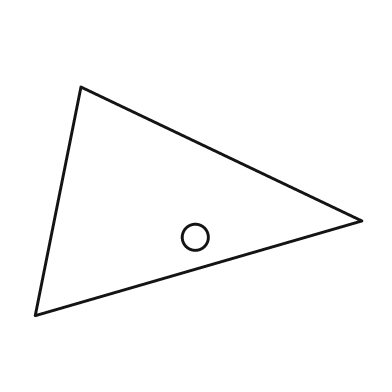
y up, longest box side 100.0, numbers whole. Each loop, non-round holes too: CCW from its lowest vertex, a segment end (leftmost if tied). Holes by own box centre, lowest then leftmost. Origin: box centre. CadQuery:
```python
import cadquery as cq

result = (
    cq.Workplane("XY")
    .moveTo(-50.0, -35.0)
    .lineTo(50.0, -6.0)
    .lineTo(-36.0, 35.0)
    .close()
    .moveTo(-1.0, -11.0)
    .circle(4.0)
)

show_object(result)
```